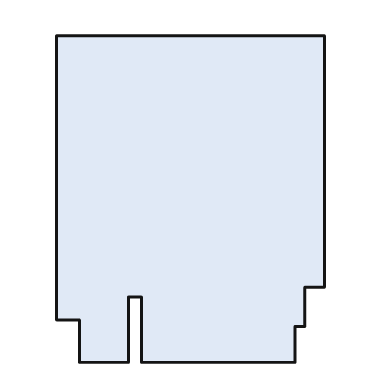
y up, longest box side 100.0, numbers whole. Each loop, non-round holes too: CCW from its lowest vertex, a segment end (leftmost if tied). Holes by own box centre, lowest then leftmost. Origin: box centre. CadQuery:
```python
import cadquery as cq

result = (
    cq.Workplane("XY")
    .moveTo(-34.0, -50.0)
    .lineTo(-19.0, -50.0)
    .lineTo(-19.0, -30.0)
    .lineTo(-15.0, -30.0)
    .lineTo(-15.0, -50.0)
    .lineTo(32.0, -50.0)
    .lineTo(32.0, -39.0)
    .lineTo(35.0, -39.0)
    .lineTo(35.0, -27.0)
    .lineTo(41.0, -27.0)
    .lineTo(41.0, 50.0)
    .lineTo(-41.0, 50.0)
    .lineTo(-41.0, -37.0)
    .lineTo(-34.0, -37.0)
    .close()
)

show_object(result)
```